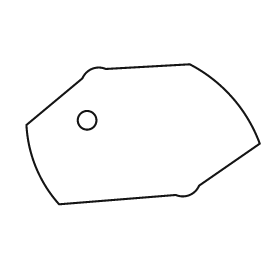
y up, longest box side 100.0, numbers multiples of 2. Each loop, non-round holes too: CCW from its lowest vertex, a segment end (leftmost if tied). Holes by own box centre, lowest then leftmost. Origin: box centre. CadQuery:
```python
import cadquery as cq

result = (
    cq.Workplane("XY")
    .moveTo(-36.0, -30.0)
    .lineTo(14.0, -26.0)
    .threePointArc((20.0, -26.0), (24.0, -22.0))
    .lineTo(50.0, -4.0)
    .threePointArc((38.0, 16.0), (20.0, 30.0))
    .lineTo(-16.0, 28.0)
    .threePointArc((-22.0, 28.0), (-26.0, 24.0))
    .lineTo(-50.0, 4.0)
    .threePointArc((-46.0, -14.0), (-36.0, -30.0))
    .close()
    .moveTo(-24.0, 6.0)
    .circle(4.0)
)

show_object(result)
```